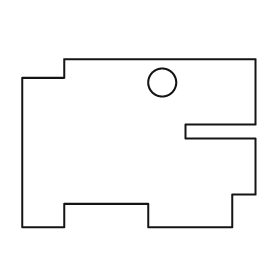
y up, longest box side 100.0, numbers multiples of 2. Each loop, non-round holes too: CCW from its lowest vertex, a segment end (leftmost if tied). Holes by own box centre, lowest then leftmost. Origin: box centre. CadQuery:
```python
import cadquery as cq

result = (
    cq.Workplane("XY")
    .moveTo(-50.0, -36.0)
    .lineTo(-32.0, -36.0)
    .lineTo(-32.0, -26.0)
    .lineTo(4.0, -26.0)
    .lineTo(4.0, -36.0)
    .lineTo(40.0, -36.0)
    .lineTo(40.0, -22.0)
    .lineTo(50.0, -22.0)
    .lineTo(50.0, 2.0)
    .lineTo(20.0, 2.0)
    .lineTo(20.0, 8.0)
    .lineTo(50.0, 8.0)
    .lineTo(50.0, 36.0)
    .lineTo(-32.0, 36.0)
    .lineTo(-32.0, 28.0)
    .lineTo(-50.0, 28.0)
    .close()
    .moveTo(10.0, 26.0)
    .circle(6.0)
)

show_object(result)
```